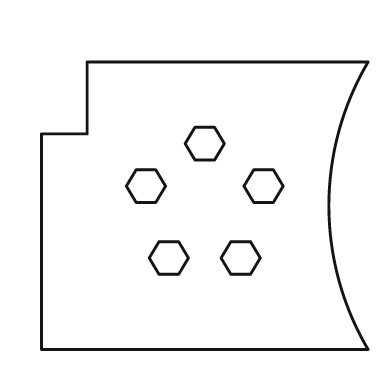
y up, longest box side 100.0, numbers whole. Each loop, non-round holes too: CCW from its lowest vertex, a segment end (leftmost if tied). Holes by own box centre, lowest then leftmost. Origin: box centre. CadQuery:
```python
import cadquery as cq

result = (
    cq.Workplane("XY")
    .moveTo(-50.0, -44.0)
    .lineTo(50.0, -44.0)
    .threePointArc((38.0, 0.0), (50.0, 44.0))
    .lineTo(-36.0, 44.0)
    .lineTo(-36.0, 22.0)
    .lineTo(-50.0, 22.0)
    .close()
    .moveTo(-14.0, -21.0)
    .lineTo(-8.0, -21.0)
    .lineTo(-5.0, -16.0)
    .lineTo(-8.0, -11.0)
    .lineTo(-14.0, -11.0)
    .lineTo(-17.0, -16.0)
    .close()
    .moveTo(8.0, -21.0)
    .lineTo(14.0, -21.0)
    .lineTo(17.0, -16.0)
    .lineTo(14.0, -11.0)
    .lineTo(8.0, -11.0)
    .lineTo(5.0, -16.0)
    .close()
    .moveTo(-21.0, 1.0)
    .lineTo(-15.0, 1.0)
    .lineTo(-12.0, 6.0)
    .lineTo(-15.0, 11.0)
    .lineTo(-21.0, 11.0)
    .lineTo(-24.0, 6.0)
    .close()
    .moveTo(15.0, 1.0)
    .lineTo(21.0, 1.0)
    .lineTo(24.0, 6.0)
    .lineTo(21.0, 11.0)
    .lineTo(15.0, 11.0)
    .lineTo(12.0, 6.0)
    .close()
    .moveTo(-3.0, 14.0)
    .lineTo(3.0, 14.0)
    .lineTo(6.0, 19.0)
    .lineTo(3.0, 24.0)
    .lineTo(-3.0, 24.0)
    .lineTo(-6.0, 19.0)
    .close()
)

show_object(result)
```